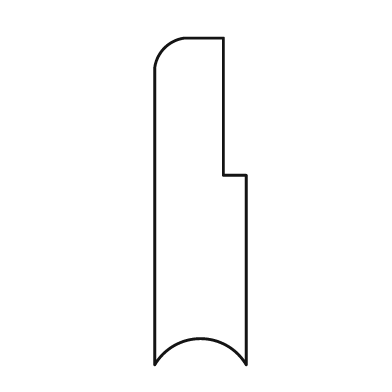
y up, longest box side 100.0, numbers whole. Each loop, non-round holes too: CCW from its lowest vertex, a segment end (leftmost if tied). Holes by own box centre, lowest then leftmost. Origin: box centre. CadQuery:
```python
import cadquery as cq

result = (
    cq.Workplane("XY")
    .moveTo(-14.0, -50.0)
    .threePointArc((0.0, -42.0), (14.0, -50.0))
    .lineTo(14.0, 8.0)
    .lineTo(7.0, 8.0)
    .lineTo(7.0, 50.0)
    .lineTo(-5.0, 50.0)
    .threePointArc((-11.0, 47.0), (-14.0, 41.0))
    .close()
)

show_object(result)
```